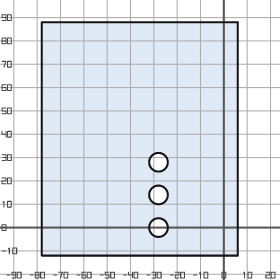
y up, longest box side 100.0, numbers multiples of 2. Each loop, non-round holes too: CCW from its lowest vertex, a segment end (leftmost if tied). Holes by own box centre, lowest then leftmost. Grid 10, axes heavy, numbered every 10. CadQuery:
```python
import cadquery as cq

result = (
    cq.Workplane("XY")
    .moveTo(-78.0, -12.0)
    .lineTo(6.0, -12.0)
    .lineTo(6.0, 88.0)
    .lineTo(-78.0, 88.0)
    .close()
    .moveTo(-28.0, 0.0)
    .circle(4.0)
    .moveTo(-28.0, 14.0)
    .circle(4.0)
    .moveTo(-28.0, 28.0)
    .circle(4.0)
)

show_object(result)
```